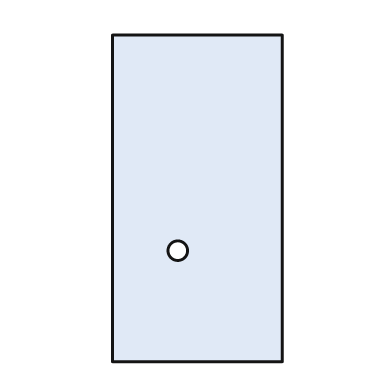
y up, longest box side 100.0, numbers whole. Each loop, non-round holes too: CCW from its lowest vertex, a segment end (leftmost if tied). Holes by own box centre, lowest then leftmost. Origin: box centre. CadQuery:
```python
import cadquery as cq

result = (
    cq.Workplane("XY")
    .moveTo(-26.0, -50.0)
    .lineTo(26.0, -50.0)
    .lineTo(26.0, 50.0)
    .lineTo(-26.0, 50.0)
    .close()
    .moveTo(-6.0, -16.0)
    .circle(3.0)
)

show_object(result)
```